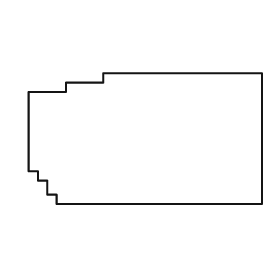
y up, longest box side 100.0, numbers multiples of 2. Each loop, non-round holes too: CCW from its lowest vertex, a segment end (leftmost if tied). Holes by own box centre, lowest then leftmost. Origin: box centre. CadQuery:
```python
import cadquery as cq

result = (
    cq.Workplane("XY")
    .moveTo(-38.0, -28.0)
    .lineTo(50.0, -28.0)
    .lineTo(50.0, 28.0)
    .lineTo(-18.0, 28.0)
    .lineTo(-18.0, 24.0)
    .lineTo(-34.0, 24.0)
    .lineTo(-34.0, 20.0)
    .lineTo(-50.0, 20.0)
    .lineTo(-50.0, -14.0)
    .lineTo(-46.0, -14.0)
    .lineTo(-46.0, -18.0)
    .lineTo(-42.0, -18.0)
    .lineTo(-42.0, -24.0)
    .lineTo(-38.0, -24.0)
    .close()
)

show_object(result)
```